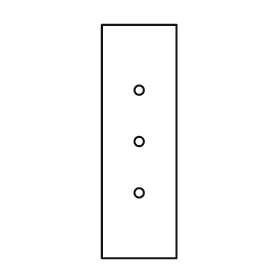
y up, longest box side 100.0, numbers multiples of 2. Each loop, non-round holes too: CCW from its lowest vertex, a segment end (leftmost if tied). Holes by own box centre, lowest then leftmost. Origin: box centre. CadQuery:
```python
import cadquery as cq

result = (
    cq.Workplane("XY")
    .moveTo(-16.0, -50.0)
    .lineTo(16.0, -50.0)
    .lineTo(16.0, 50.0)
    .lineTo(-16.0, 50.0)
    .close()
    .moveTo(0.0, -22.0)
    .circle(2.0)
    .moveTo(0.0, 0.0)
    .circle(2.0)
    .moveTo(0.0, 22.0)
    .circle(2.0)
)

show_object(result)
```